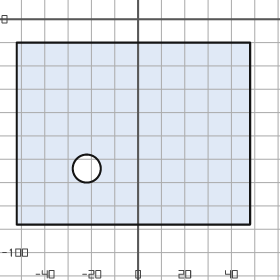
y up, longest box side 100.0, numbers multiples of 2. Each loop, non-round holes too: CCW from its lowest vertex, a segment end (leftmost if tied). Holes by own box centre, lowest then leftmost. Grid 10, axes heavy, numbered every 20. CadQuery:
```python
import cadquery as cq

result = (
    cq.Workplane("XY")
    .moveTo(-52.0, -88.0)
    .lineTo(48.0, -88.0)
    .lineTo(48.0, -10.0)
    .lineTo(-52.0, -10.0)
    .close()
    .moveTo(-22.0, -64.0)
    .circle(6.0)
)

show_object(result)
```